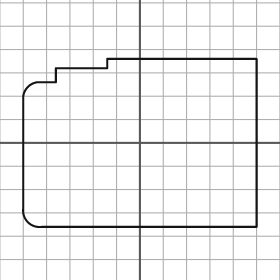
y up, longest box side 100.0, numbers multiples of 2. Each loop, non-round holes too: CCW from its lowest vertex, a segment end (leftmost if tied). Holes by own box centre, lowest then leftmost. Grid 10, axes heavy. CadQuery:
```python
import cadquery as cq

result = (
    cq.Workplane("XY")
    .moveTo(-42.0, -36.0)
    .lineTo(50.0, -36.0)
    .lineTo(50.0, 36.0)
    .lineTo(-14.0, 36.0)
    .lineTo(-14.0, 32.0)
    .lineTo(-36.0, 32.0)
    .lineTo(-36.0, 26.0)
    .lineTo(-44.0, 26.0)
    .threePointArc((-48.0, 24.0), (-50.0, 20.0))
    .lineTo(-50.0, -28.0)
    .threePointArc((-48.0, -34.0), (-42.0, -36.0))
    .close()
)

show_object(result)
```